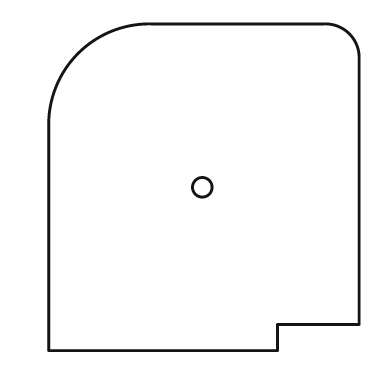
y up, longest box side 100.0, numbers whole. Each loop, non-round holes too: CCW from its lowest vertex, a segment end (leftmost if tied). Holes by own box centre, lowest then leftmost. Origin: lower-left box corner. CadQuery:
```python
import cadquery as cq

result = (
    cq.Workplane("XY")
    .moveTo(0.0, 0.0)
    .lineTo(70.0, 0.0)
    .lineTo(70.0, 8.0)
    .lineTo(95.0, 8.0)
    .lineTo(95.0, 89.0)
    .threePointArc((92.0, 97.0), (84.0, 100.0))
    .lineTo(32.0, 100.0)
    .threePointArc((9.0, 91.0), (0.0, 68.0))
    .close()
    .moveTo(47.0, 50.0)
    .circle(3.0)
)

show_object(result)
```